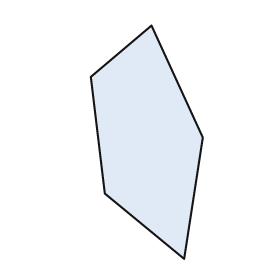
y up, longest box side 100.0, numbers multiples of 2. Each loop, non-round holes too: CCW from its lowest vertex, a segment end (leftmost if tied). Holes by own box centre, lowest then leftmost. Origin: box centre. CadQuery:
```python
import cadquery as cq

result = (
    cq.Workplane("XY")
    .moveTo(16.0, -50.0)
    .lineTo(24.0, 2.0)
    .lineTo(2.0, 50.0)
    .lineTo(-24.0, 28.0)
    .lineTo(-18.0, -22.0)
    .close()
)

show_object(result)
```